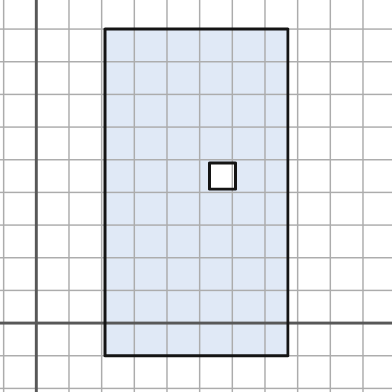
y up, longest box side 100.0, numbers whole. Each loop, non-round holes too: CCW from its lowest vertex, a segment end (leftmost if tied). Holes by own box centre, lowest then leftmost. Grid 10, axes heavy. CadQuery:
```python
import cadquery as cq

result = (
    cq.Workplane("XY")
    .moveTo(21.0, -10.0)
    .lineTo(77.0, -10.0)
    .lineTo(77.0, 90.0)
    .lineTo(21.0, 90.0)
    .close()
    .moveTo(53.0, 41.0)
    .lineTo(61.0, 41.0)
    .lineTo(61.0, 49.0)
    .lineTo(53.0, 49.0)
    .close()
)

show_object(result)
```